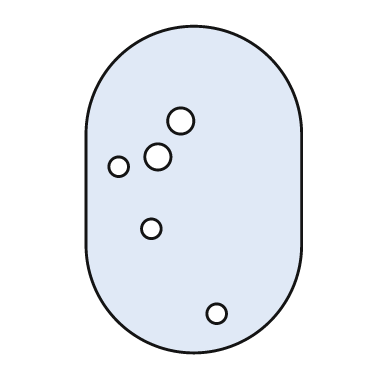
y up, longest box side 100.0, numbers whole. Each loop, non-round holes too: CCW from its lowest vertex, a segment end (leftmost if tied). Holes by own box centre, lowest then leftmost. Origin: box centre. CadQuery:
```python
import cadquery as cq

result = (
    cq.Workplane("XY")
    .moveTo(-33.0, -17.0)
    .threePointArc((0.0, -50.0), (33.0, -17.0))
    .lineTo(33.0, 17.0)
    .threePointArc((0.0, 50.0), (-33.0, 17.0))
    .close()
    .moveTo(7.0, -38.0)
    .circle(3.0)
    .moveTo(-13.0, -12.0)
    .circle(3.0)
    .moveTo(-23.0, 7.0)
    .circle(3.0)
    .moveTo(-11.0, 10.0)
    .circle(4.0)
    .moveTo(-4.0, 21.0)
    .circle(4.0)
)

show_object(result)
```